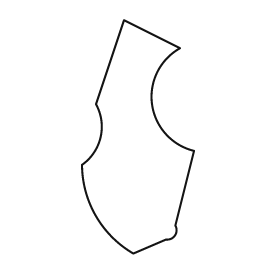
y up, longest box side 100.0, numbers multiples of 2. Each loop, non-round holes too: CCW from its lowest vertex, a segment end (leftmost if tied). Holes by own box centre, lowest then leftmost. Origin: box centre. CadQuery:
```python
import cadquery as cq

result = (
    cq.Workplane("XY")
    .moveTo(-2.0, -50.0)
    .lineTo(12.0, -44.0)
    .threePointArc((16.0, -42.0), (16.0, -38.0))
    .lineTo(24.0, -6.0)
    .threePointArc((6.0, 14.0), (18.0, 38.0))
    .lineTo(-6.0, 50.0)
    .lineTo(-18.0, 14.0)
    .threePointArc((-16.0, 0.0), (-24.0, -12.0))
    .threePointArc((-18.0, -34.0), (-2.0, -50.0))
    .close()
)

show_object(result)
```